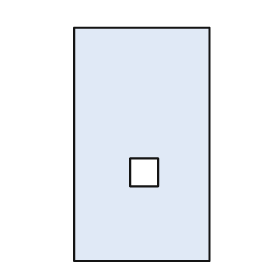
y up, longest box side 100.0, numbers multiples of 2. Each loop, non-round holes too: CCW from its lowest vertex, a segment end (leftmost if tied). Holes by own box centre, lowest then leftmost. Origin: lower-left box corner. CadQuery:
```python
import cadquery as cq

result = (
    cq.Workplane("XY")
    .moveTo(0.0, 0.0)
    .lineTo(58.0, 0.0)
    .lineTo(58.0, 100.0)
    .lineTo(0.0, 100.0)
    .close()
    .moveTo(24.0, 32.0)
    .lineTo(36.0, 32.0)
    .lineTo(36.0, 44.0)
    .lineTo(24.0, 44.0)
    .close()
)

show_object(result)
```